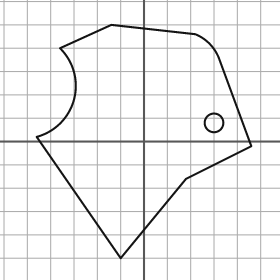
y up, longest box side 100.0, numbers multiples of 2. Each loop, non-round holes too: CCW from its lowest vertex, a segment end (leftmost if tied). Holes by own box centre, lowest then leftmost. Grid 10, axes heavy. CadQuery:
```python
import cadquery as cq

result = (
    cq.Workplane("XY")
    .moveTo(-10.0, -50.0)
    .lineTo(18.0, -16.0)
    .lineTo(46.0, -2.0)
    .lineTo(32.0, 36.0)
    .threePointArc((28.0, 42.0), (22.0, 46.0))
    .lineTo(-14.0, 50.0)
    .lineTo(-36.0, 40.0)
    .threePointArc((-30.0, 18.0), (-46.0, 2.0))
    .close()
    .moveTo(30.0, 8.0)
    .circle(4.0)
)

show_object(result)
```